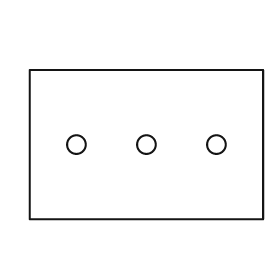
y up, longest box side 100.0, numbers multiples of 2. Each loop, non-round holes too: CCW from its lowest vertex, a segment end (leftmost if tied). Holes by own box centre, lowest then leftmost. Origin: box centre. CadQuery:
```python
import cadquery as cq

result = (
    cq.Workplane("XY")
    .moveTo(-50.0, -32.0)
    .lineTo(50.0, -32.0)
    .lineTo(50.0, 32.0)
    .lineTo(-50.0, 32.0)
    .close()
    .moveTo(-30.0, 0.0)
    .circle(4.0)
    .moveTo(0.0, 0.0)
    .circle(4.0)
    .moveTo(30.0, 0.0)
    .circle(4.0)
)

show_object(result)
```